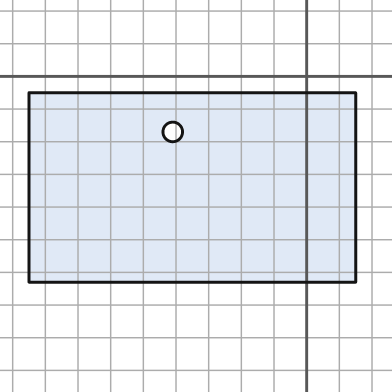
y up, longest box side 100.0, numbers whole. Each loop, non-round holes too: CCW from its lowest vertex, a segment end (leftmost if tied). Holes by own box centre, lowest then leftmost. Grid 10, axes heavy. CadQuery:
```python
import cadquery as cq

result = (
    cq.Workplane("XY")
    .moveTo(-85.0, -63.0)
    .lineTo(15.0, -63.0)
    .lineTo(15.0, -5.0)
    .lineTo(-85.0, -5.0)
    .close()
    .moveTo(-41.0, -17.0)
    .circle(3.0)
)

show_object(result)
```